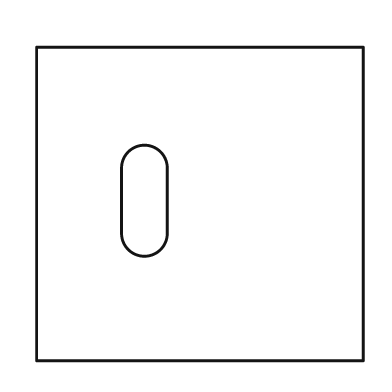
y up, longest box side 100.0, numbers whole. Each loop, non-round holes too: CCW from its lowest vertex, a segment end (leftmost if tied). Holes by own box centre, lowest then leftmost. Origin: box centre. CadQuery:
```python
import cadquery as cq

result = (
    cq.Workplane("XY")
    .moveTo(-50.0, -48.0)
    .lineTo(50.0, -48.0)
    .lineTo(50.0, 48.0)
    .lineTo(-50.0, 48.0)
    .close()
    .moveTo(-24.0, -9.0)
    .threePointArc((-17.0, -16.0), (-10.0, -9.0))
    .lineTo(-10.0, 11.0)
    .threePointArc((-17.0, 18.0), (-24.0, 11.0))
    .close()
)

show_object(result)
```